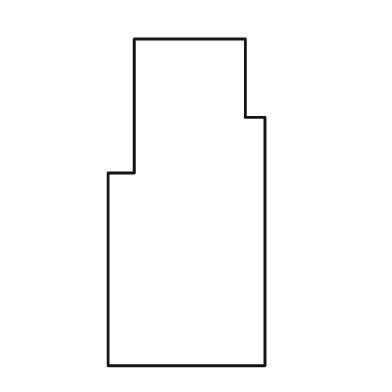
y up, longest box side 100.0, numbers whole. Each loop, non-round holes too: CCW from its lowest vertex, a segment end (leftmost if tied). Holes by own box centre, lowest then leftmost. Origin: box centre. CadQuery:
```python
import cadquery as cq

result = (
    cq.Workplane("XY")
    .moveTo(-24.0, -50.0)
    .lineTo(24.0, -50.0)
    .lineTo(24.0, 26.0)
    .lineTo(18.0, 26.0)
    .lineTo(18.0, 50.0)
    .lineTo(-16.0, 50.0)
    .lineTo(-16.0, 9.0)
    .lineTo(-24.0, 9.0)
    .close()
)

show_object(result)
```